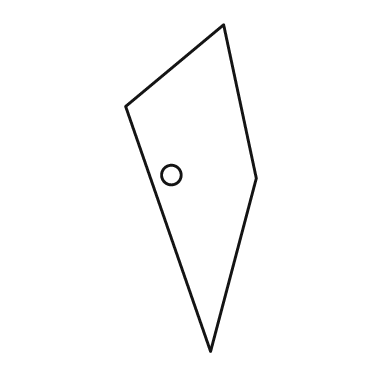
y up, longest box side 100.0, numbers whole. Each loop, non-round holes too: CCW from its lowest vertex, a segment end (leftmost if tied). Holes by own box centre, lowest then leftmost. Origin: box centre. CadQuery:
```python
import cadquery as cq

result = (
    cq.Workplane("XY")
    .moveTo(6.0, -50.0)
    .lineTo(20.0, 3.0)
    .lineTo(10.0, 50.0)
    .lineTo(-20.0, 25.0)
    .close()
    .moveTo(-6.0, 4.0)
    .circle(3.0)
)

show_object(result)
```